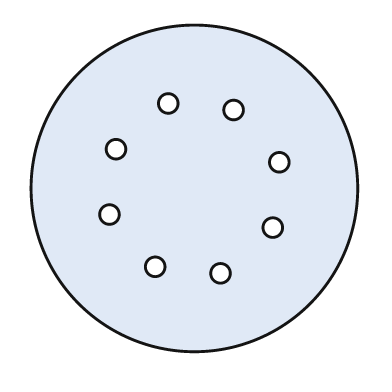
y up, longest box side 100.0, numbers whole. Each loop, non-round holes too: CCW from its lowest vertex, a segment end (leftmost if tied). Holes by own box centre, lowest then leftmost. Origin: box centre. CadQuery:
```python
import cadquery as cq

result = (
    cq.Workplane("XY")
    .moveTo(0.0, 0.0)
    .circle(50.0)
    .moveTo(8.0, -26.0)
    .circle(3.0)
    .moveTo(-12.0, -24.0)
    .circle(3.0)
    .moveTo(24.0, -12.0)
    .circle(3.0)
    .moveTo(-26.0, -8.0)
    .circle(3.0)
    .moveTo(26.0, 8.0)
    .circle(3.0)
    .moveTo(-24.0, 12.0)
    .circle(3.0)
    .moveTo(12.0, 24.0)
    .circle(3.0)
    .moveTo(-8.0, 26.0)
    .circle(3.0)
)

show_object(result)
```